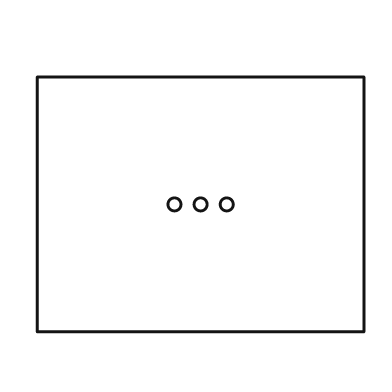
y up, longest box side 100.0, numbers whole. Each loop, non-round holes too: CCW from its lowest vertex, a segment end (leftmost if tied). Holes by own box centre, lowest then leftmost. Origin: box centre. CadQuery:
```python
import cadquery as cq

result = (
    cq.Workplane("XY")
    .moveTo(-50.0, -39.0)
    .lineTo(50.0, -39.0)
    .lineTo(50.0, 39.0)
    .lineTo(-50.0, 39.0)
    .close()
    .moveTo(-8.0, 0.0)
    .circle(2.0)
    .moveTo(0.0, 0.0)
    .circle(2.0)
    .moveTo(8.0, 0.0)
    .circle(2.0)
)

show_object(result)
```